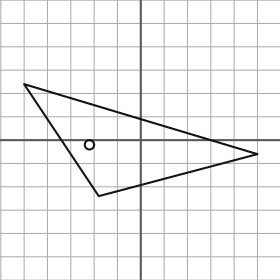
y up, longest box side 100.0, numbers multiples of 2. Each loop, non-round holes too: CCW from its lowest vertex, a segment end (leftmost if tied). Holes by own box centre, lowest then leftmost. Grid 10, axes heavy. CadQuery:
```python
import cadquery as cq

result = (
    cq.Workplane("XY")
    .moveTo(-18.0, -24.0)
    .lineTo(50.0, -6.0)
    .lineTo(-50.0, 24.0)
    .close()
    .moveTo(-22.0, -2.0)
    .circle(2.0)
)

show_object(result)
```